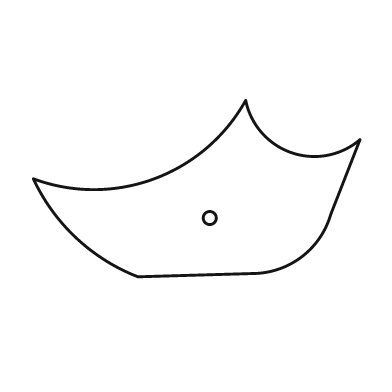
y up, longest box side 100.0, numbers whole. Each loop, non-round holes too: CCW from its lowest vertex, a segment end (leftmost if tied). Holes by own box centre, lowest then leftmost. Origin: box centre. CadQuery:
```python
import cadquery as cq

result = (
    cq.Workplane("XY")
    .moveTo(-18.0, -27.0)
    .lineTo(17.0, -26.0)
    .threePointArc((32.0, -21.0), (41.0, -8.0))
    .lineTo(50.0, 15.0)
    .threePointArc((29.0, 11.0), (15.0, 27.0))
    .threePointArc((-13.0, 3.0), (-50.0, 3.0))
    .threePointArc((-37.0, -15.0), (-18.0, -27.0))
    .close()
    .moveTo(4.0, -9.0)
    .circle(2.0)
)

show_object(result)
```